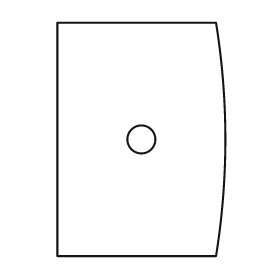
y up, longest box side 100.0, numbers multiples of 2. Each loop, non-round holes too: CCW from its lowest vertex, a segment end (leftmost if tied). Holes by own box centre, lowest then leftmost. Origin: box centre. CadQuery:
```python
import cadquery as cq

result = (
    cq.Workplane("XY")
    .moveTo(-36.0, -50.0)
    .lineTo(32.0, -50.0)
    .threePointArc((36.0, 0.0), (32.0, 50.0))
    .lineTo(-36.0, 50.0)
    .close()
    .moveTo(0.0, 0.0)
    .circle(6.0)
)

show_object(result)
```